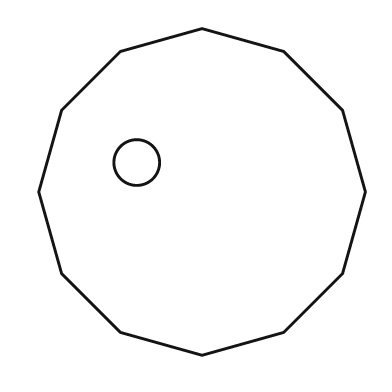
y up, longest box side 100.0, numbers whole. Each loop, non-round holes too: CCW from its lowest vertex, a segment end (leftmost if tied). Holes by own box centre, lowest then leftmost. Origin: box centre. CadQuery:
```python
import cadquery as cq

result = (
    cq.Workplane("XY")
    .moveTo(0.0, -50.0)
    .lineTo(25.0, -43.0)
    .lineTo(43.0, -25.0)
    .lineTo(50.0, 0.0)
    .lineTo(43.0, 25.0)
    .lineTo(25.0, 43.0)
    .lineTo(0.0, 50.0)
    .lineTo(-25.0, 43.0)
    .lineTo(-43.0, 25.0)
    .lineTo(-50.0, 0.0)
    .lineTo(-43.0, -25.0)
    .lineTo(-25.0, -43.0)
    .close()
    .moveTo(-20.0, 9.0)
    .circle(7.0)
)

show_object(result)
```